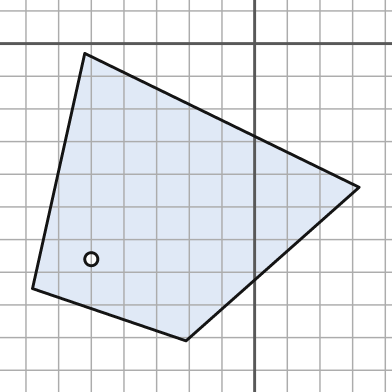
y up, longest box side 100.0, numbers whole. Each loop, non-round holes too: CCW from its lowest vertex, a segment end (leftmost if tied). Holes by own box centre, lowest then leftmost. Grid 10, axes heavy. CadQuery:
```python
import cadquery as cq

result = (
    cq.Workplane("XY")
    .moveTo(-21.0, -91.0)
    .lineTo(32.0, -44.0)
    .lineTo(-52.0, -3.0)
    .lineTo(-68.0, -75.0)
    .close()
    .moveTo(-50.0, -66.0)
    .circle(2.0)
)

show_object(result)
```